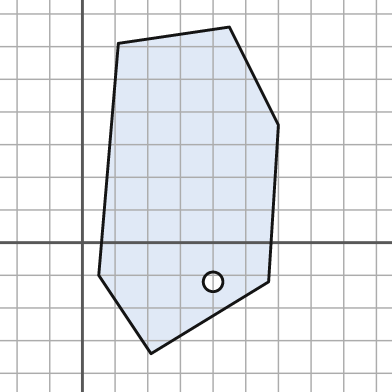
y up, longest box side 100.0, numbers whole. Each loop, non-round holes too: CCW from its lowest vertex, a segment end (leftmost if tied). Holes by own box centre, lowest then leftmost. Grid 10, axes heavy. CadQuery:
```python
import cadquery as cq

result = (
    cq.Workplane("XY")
    .moveTo(21.0, -34.0)
    .lineTo(57.0, -12.0)
    .lineTo(60.0, 36.0)
    .lineTo(45.0, 66.0)
    .lineTo(11.0, 61.0)
    .lineTo(5.0, -10.0)
    .close()
    .moveTo(40.0, -12.0)
    .circle(3.0)
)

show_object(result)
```